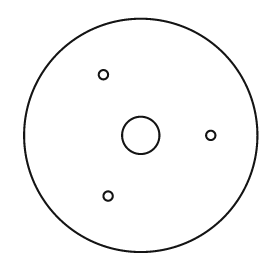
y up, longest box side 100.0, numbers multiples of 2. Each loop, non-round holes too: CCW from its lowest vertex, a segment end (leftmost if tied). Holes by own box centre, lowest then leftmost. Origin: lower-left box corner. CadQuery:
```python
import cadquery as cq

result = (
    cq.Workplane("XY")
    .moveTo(50.0, 50.0)
    .circle(50.0)
    .moveTo(36.0, 24.0)
    .circle(2.0)
    .moveTo(50.0, 50.0)
    .circle(8.0)
    .moveTo(80.0, 50.0)
    .circle(2.0)
    .moveTo(34.0, 76.0)
    .circle(2.0)
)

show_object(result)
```